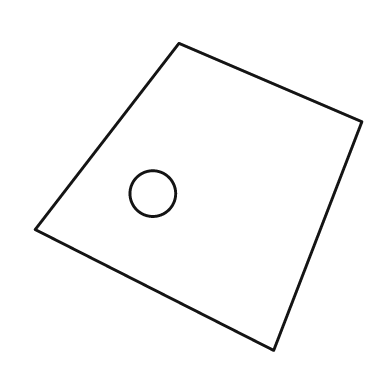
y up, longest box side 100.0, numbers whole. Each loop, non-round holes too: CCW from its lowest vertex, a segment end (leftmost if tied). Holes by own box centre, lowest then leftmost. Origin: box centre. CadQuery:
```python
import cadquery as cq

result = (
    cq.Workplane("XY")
    .moveTo(23.0, -47.0)
    .lineTo(50.0, 23.0)
    .lineTo(-6.0, 47.0)
    .lineTo(-50.0, -10.0)
    .close()
    .moveTo(-14.0, 1.0)
    .circle(7.0)
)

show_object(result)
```